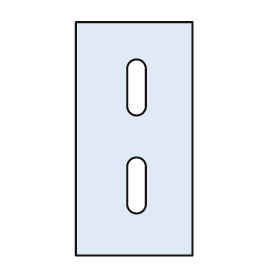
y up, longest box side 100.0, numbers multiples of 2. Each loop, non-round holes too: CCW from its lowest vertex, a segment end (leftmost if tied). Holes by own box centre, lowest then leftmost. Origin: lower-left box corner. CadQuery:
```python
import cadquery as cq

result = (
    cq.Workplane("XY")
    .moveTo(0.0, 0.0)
    .lineTo(50.0, 0.0)
    .lineTo(50.0, 100.0)
    .lineTo(0.0, 100.0)
    .close()
    .moveTo(22.0, 22.0)
    .threePointArc((26.0, 18.0), (30.0, 22.0))
    .lineTo(30.0, 38.0)
    .threePointArc((26.0, 42.0), (22.0, 38.0))
    .close()
    .moveTo(22.0, 64.0)
    .threePointArc((26.0, 60.0), (30.0, 64.0))
    .lineTo(30.0, 80.0)
    .threePointArc((26.0, 84.0), (22.0, 80.0))
    .close()
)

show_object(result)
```